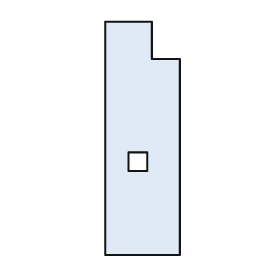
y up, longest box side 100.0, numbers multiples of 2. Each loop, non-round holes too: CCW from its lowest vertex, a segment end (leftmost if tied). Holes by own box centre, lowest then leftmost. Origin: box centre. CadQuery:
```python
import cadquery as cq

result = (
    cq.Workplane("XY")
    .moveTo(-16.0, -50.0)
    .lineTo(16.0, -50.0)
    .lineTo(16.0, 34.0)
    .lineTo(4.0, 34.0)
    .lineTo(4.0, 50.0)
    .lineTo(-16.0, 50.0)
    .close()
    .moveTo(-6.0, -14.0)
    .lineTo(2.0, -14.0)
    .lineTo(2.0, -6.0)
    .lineTo(-6.0, -6.0)
    .close()
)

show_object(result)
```